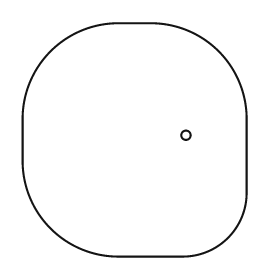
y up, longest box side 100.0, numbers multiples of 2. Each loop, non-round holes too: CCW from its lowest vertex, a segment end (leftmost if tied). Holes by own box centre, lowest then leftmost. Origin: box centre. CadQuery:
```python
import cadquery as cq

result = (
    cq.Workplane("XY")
    .moveTo(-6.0, -50.0)
    .lineTo(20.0, -50.0)
    .threePointArc((40.0, -42.0), (48.0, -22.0))
    .lineTo(48.0, 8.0)
    .threePointArc((36.0, 38.0), (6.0, 50.0))
    .lineTo(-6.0, 50.0)
    .threePointArc((-36.0, 38.0), (-48.0, 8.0))
    .lineTo(-48.0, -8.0)
    .threePointArc((-36.0, -38.0), (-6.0, -50.0))
    .close()
    .moveTo(22.0, 2.0)
    .circle(2.0)
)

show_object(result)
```